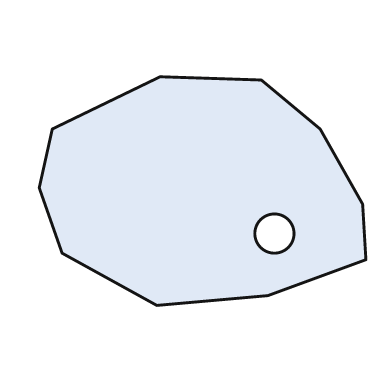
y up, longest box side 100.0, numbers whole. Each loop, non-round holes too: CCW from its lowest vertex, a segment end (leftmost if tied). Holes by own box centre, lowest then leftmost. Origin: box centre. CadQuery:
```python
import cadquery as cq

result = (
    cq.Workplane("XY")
    .moveTo(-14.0, -35.0)
    .lineTo(20.0, -32.0)
    .lineTo(50.0, -21.0)
    .lineTo(49.0, -4.0)
    .lineTo(36.0, 19.0)
    .lineTo(18.0, 34.0)
    .lineTo(-13.0, 35.0)
    .lineTo(-46.0, 19.0)
    .lineTo(-50.0, 1.0)
    .lineTo(-43.0, -19.0)
    .close()
    .moveTo(22.0, -13.0)
    .circle(6.0)
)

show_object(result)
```